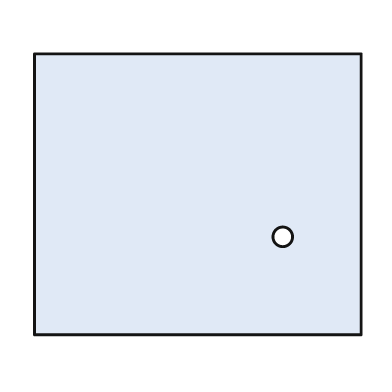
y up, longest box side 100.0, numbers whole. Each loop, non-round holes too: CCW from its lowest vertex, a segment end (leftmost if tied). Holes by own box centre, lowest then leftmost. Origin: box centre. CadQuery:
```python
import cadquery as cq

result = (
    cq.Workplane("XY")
    .moveTo(-50.0, -43.0)
    .lineTo(50.0, -43.0)
    .lineTo(50.0, 43.0)
    .lineTo(-50.0, 43.0)
    .close()
    .moveTo(26.0, -13.0)
    .circle(3.0)
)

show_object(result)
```